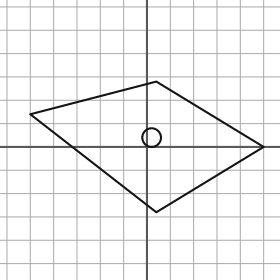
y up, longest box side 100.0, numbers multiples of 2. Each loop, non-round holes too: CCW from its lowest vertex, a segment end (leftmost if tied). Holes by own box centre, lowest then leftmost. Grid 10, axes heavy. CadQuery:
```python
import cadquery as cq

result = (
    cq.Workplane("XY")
    .moveTo(4.0, -28.0)
    .lineTo(50.0, 0.0)
    .lineTo(4.0, 28.0)
    .lineTo(-50.0, 14.0)
    .close()
    .moveTo(2.0, 4.0)
    .circle(4.0)
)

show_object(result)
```